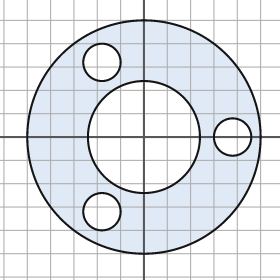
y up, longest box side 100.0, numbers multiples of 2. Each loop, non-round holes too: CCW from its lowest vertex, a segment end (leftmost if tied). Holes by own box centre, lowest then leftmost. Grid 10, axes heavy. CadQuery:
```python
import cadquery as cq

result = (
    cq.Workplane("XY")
    .moveTo(0.0, 0.0)
    .circle(50.0)
    .moveTo(-18.0, -32.0)
    .circle(8.0)
    .moveTo(0.0, 0.0)
    .circle(24.0)
    .moveTo(38.0, 0.0)
    .circle(8.0)
    .moveTo(-18.0, 32.0)
    .circle(8.0)
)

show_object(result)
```